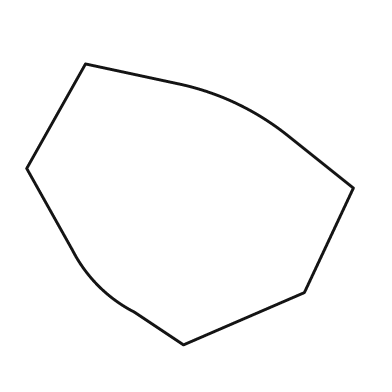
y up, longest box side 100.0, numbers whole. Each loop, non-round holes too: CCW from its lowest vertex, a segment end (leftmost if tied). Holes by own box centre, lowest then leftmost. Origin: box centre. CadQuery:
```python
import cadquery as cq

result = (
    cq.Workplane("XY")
    .moveTo(-2.0, -43.0)
    .lineTo(35.0, -27.0)
    .lineTo(50.0, 5.0)
    .lineTo(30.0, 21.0)
    .threePointArc((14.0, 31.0), (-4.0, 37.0))
    .lineTo(-32.0, 43.0)
    .lineTo(-50.0, 11.0)
    .lineTo(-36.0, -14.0)
    .threePointArc((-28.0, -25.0), (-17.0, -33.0))
    .close()
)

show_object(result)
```